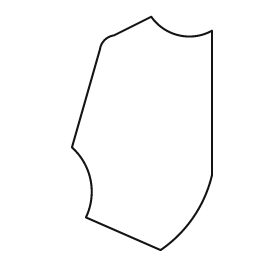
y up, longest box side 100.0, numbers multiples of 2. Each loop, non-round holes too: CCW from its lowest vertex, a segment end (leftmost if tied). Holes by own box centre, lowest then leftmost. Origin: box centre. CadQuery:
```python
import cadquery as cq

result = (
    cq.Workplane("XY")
    .moveTo(8.0, -50.0)
    .threePointArc((22.0, -36.0), (30.0, -18.0))
    .lineTo(30.0, 44.0)
    .threePointArc((16.0, 42.0), (4.0, 50.0))
    .lineTo(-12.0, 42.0)
    .threePointArc((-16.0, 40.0), (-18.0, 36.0))
    .lineTo(-30.0, -6.0)
    .threePointArc((-22.0, -20.0), (-24.0, -36.0))
    .close()
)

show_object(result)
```